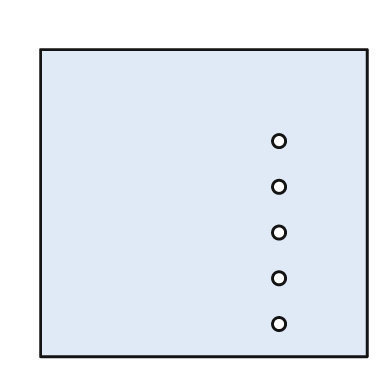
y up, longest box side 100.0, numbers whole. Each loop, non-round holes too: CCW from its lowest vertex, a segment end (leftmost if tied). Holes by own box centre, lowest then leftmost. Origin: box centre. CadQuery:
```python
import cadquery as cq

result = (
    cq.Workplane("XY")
    .moveTo(-50.0, -47.0)
    .lineTo(50.0, -47.0)
    .lineTo(50.0, 47.0)
    .lineTo(-50.0, 47.0)
    .close()
    .moveTo(23.0, -37.0)
    .circle(2.0)
    .moveTo(23.0, -23.0)
    .circle(2.0)
    .moveTo(23.0, -9.0)
    .circle(2.0)
    .moveTo(23.0, 5.0)
    .circle(2.0)
    .moveTo(23.0, 19.0)
    .circle(2.0)
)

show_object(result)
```